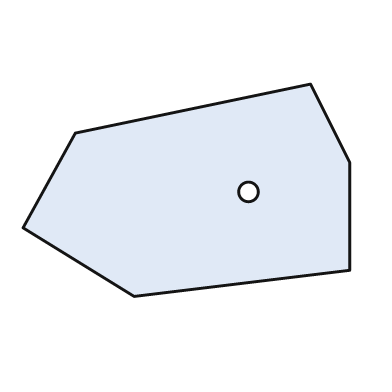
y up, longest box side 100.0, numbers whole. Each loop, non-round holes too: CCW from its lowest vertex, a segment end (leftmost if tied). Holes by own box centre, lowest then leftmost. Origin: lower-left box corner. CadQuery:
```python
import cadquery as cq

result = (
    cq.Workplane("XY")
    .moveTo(34.0, 0.0)
    .lineTo(100.0, 8.0)
    .lineTo(100.0, 41.0)
    .lineTo(88.0, 65.0)
    .lineTo(16.0, 50.0)
    .lineTo(0.0, 21.0)
    .close()
    .moveTo(69.0, 32.0)
    .circle(3.0)
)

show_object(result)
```